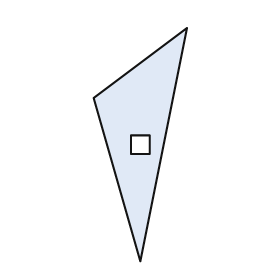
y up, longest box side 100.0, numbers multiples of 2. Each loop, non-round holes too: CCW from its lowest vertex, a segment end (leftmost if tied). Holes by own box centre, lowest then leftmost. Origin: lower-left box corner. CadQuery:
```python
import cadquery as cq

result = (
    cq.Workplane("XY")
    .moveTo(20.0, 0.0)
    .lineTo(40.0, 100.0)
    .lineTo(0.0, 70.0)
    .close()
    .moveTo(16.0, 46.0)
    .lineTo(24.0, 46.0)
    .lineTo(24.0, 54.0)
    .lineTo(16.0, 54.0)
    .close()
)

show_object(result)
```